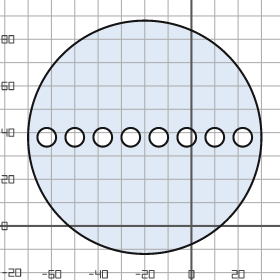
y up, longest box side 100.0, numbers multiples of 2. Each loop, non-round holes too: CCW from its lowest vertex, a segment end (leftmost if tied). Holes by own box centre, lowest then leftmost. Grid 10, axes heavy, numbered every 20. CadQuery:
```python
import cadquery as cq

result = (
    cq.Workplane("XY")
    .moveTo(-20.0, 38.0)
    .circle(50.0)
    .moveTo(-62.0, 38.0)
    .circle(4.0)
    .moveTo(-50.0, 38.0)
    .circle(4.0)
    .moveTo(-38.0, 38.0)
    .circle(4.0)
    .moveTo(-26.0, 38.0)
    .circle(4.0)
    .moveTo(-14.0, 38.0)
    .circle(4.0)
    .moveTo(-2.0, 38.0)
    .circle(4.0)
    .moveTo(10.0, 38.0)
    .circle(4.0)
    .moveTo(22.0, 38.0)
    .circle(4.0)
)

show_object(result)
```